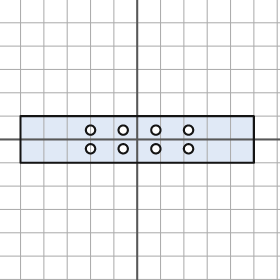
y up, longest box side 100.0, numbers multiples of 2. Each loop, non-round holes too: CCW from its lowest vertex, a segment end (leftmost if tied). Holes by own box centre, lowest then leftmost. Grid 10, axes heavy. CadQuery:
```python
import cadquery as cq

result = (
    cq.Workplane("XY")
    .moveTo(-50.0, -10.0)
    .lineTo(50.0, -10.0)
    .lineTo(50.0, 10.0)
    .lineTo(-50.0, 10.0)
    .close()
    .moveTo(-20.0, -4.0)
    .circle(2.0)
    .moveTo(-6.0, -4.0)
    .circle(2.0)
    .moveTo(8.0, -4.0)
    .circle(2.0)
    .moveTo(22.0, -4.0)
    .circle(2.0)
    .moveTo(-20.0, 4.0)
    .circle(2.0)
    .moveTo(-6.0, 4.0)
    .circle(2.0)
    .moveTo(8.0, 4.0)
    .circle(2.0)
    .moveTo(22.0, 4.0)
    .circle(2.0)
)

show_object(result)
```